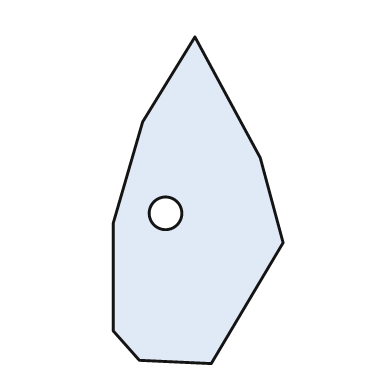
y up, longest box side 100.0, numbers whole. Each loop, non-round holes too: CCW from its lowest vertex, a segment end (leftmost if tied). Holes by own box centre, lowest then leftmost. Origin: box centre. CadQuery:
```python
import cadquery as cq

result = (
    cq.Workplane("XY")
    .moveTo(4.0, -50.0)
    .lineTo(26.0, -13.0)
    .lineTo(19.0, 13.0)
    .lineTo(-1.0, 50.0)
    .lineTo(-17.0, 24.0)
    .lineTo(-26.0, -7.0)
    .lineTo(-26.0, -40.0)
    .lineTo(-18.0, -49.0)
    .close()
    .moveTo(-10.0, -4.0)
    .circle(5.0)
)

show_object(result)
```